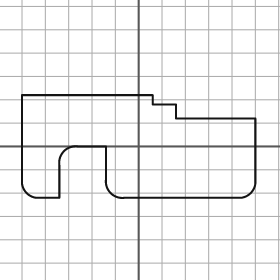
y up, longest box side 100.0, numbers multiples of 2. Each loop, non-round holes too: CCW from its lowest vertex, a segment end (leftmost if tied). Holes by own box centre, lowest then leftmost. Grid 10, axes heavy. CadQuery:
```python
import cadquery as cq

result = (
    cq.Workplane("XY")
    .moveTo(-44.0, -22.0)
    .lineTo(-34.0, -22.0)
    .lineTo(-34.0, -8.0)
    .threePointArc((-32.0, -2.0), (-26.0, 0.0))
    .lineTo(-14.0, 0.0)
    .lineTo(-14.0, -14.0)
    .threePointArc((-12.0, -20.0), (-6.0, -22.0))
    .lineTo(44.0, -22.0)
    .threePointArc((48.0, -20.0), (50.0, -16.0))
    .lineTo(50.0, 12.0)
    .lineTo(16.0, 12.0)
    .lineTo(16.0, 18.0)
    .lineTo(6.0, 18.0)
    .lineTo(6.0, 22.0)
    .lineTo(-50.0, 22.0)
    .lineTo(-50.0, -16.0)
    .threePointArc((-48.0, -20.0), (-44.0, -22.0))
    .close()
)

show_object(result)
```